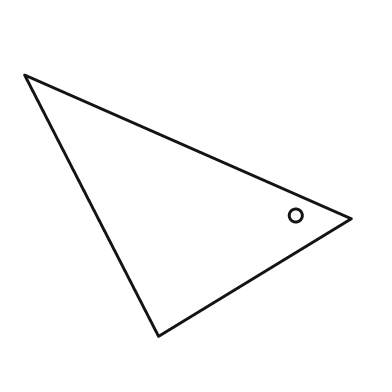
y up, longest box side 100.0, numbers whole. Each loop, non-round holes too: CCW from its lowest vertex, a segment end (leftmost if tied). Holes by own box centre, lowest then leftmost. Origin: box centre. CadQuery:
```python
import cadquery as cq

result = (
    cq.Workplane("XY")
    .moveTo(-9.0, -40.0)
    .lineTo(50.0, -4.0)
    .lineTo(-50.0, 40.0)
    .close()
    .moveTo(33.0, -3.0)
    .circle(2.0)
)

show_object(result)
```